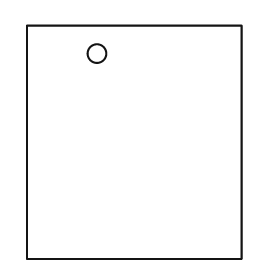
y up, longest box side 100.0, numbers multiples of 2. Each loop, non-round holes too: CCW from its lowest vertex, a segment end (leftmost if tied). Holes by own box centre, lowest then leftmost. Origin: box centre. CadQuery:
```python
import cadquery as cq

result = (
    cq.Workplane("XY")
    .moveTo(-46.0, -50.0)
    .lineTo(46.0, -50.0)
    .lineTo(46.0, 50.0)
    .lineTo(-46.0, 50.0)
    .close()
    .moveTo(-16.0, 38.0)
    .circle(4.0)
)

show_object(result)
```